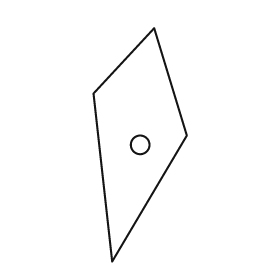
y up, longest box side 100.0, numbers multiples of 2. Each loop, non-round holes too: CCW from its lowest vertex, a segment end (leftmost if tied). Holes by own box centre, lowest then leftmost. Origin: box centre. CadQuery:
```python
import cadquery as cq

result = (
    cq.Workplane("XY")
    .moveTo(-12.0, -50.0)
    .lineTo(20.0, 4.0)
    .lineTo(6.0, 50.0)
    .lineTo(-20.0, 22.0)
    .close()
    .moveTo(0.0, 0.0)
    .circle(4.0)
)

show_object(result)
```